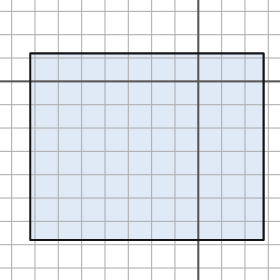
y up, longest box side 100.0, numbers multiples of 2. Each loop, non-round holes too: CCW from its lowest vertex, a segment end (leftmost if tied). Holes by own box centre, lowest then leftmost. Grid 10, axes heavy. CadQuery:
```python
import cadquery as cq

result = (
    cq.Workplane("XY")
    .moveTo(-72.0, -68.0)
    .lineTo(28.0, -68.0)
    .lineTo(28.0, 12.0)
    .lineTo(-72.0, 12.0)
    .close()
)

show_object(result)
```